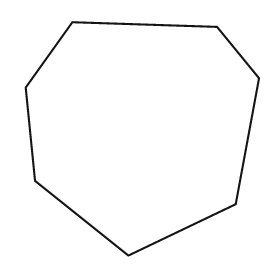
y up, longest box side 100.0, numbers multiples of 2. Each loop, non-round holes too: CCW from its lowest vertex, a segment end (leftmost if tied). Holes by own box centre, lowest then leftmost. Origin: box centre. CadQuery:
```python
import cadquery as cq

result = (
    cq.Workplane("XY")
    .moveTo(-6.0, -50.0)
    .lineTo(40.0, -28.0)
    .lineTo(50.0, 26.0)
    .lineTo(32.0, 48.0)
    .lineTo(-30.0, 50.0)
    .lineTo(-50.0, 22.0)
    .lineTo(-46.0, -18.0)
    .close()
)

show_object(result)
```